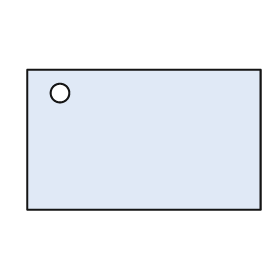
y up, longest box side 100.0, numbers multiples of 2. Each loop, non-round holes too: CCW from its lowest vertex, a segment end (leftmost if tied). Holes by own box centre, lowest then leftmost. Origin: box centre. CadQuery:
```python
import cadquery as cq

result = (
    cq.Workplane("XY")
    .moveTo(-50.0, -30.0)
    .lineTo(50.0, -30.0)
    .lineTo(50.0, 30.0)
    .lineTo(-50.0, 30.0)
    .close()
    .moveTo(-36.0, 20.0)
    .circle(4.0)
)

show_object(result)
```